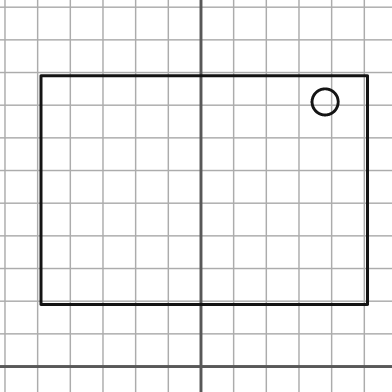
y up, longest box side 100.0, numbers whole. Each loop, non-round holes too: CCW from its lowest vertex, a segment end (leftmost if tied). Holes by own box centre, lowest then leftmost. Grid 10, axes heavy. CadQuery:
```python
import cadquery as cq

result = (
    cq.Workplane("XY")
    .moveTo(-49.0, 19.0)
    .lineTo(51.0, 19.0)
    .lineTo(51.0, 89.0)
    .lineTo(-49.0, 89.0)
    .close()
    .moveTo(38.0, 81.0)
    .circle(4.0)
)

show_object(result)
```